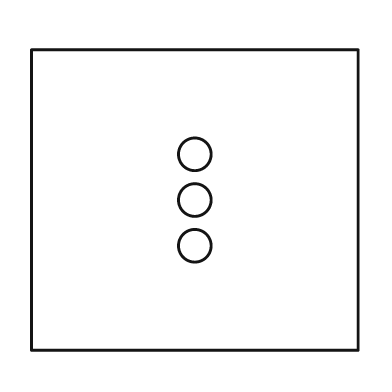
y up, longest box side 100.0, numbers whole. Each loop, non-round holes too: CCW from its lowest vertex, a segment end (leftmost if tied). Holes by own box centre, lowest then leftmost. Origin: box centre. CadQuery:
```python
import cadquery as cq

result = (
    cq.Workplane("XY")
    .moveTo(-50.0, -46.0)
    .lineTo(50.0, -46.0)
    .lineTo(50.0, 46.0)
    .lineTo(-50.0, 46.0)
    .close()
    .moveTo(0.0, -14.0)
    .circle(5.0)
    .moveTo(0.0, 0.0)
    .circle(5.0)
    .moveTo(0.0, 14.0)
    .circle(5.0)
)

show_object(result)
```